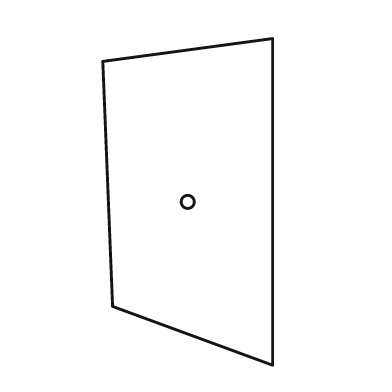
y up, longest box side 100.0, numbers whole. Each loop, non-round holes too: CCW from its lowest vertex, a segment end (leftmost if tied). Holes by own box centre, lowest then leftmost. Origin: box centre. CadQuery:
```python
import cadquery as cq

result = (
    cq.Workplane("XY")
    .moveTo(26.0, -50.0)
    .lineTo(26.0, 50.0)
    .lineTo(-26.0, 43.0)
    .lineTo(-23.0, -32.0)
    .close()
    .moveTo(0.0, 0.0)
    .circle(2.0)
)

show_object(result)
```